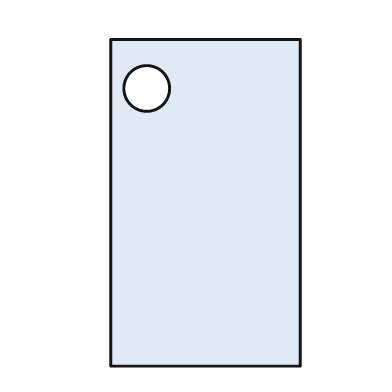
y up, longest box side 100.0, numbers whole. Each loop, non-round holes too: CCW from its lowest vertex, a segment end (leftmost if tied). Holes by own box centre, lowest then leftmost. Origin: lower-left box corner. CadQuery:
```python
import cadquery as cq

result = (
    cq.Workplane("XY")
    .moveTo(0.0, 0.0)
    .lineTo(58.0, 0.0)
    .lineTo(58.0, 100.0)
    .lineTo(0.0, 100.0)
    .close()
    .moveTo(11.0, 85.0)
    .circle(7.0)
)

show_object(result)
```